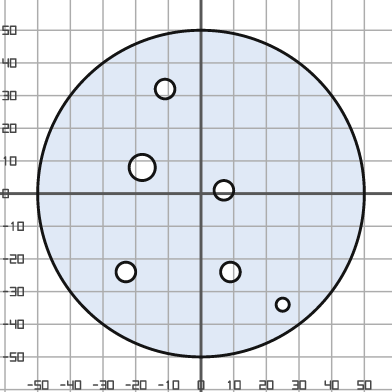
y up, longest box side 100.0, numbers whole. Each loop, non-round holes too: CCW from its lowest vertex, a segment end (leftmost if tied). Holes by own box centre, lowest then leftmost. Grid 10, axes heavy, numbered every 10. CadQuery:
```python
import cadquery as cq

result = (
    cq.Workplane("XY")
    .moveTo(0.0, 0.0)
    .circle(50.0)
    .moveTo(25.0, -34.0)
    .circle(2.0)
    .moveTo(-23.0, -24.0)
    .circle(3.0)
    .moveTo(9.0, -24.0)
    .circle(3.0)
    .moveTo(7.0, 1.0)
    .circle(3.0)
    .moveTo(-18.0, 8.0)
    .circle(4.0)
    .moveTo(-11.0, 32.0)
    .circle(3.0)
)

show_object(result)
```